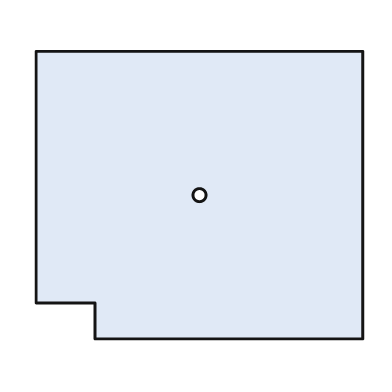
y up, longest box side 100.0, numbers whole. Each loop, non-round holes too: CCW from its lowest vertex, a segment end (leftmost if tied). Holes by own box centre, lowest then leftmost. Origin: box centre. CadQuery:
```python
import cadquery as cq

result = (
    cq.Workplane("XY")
    .moveTo(-32.0, -44.0)
    .lineTo(50.0, -44.0)
    .lineTo(50.0, 44.0)
    .lineTo(-50.0, 44.0)
    .lineTo(-50.0, -33.0)
    .lineTo(-32.0, -33.0)
    .close()
    .moveTo(0.0, 0.0)
    .circle(2.0)
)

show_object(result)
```